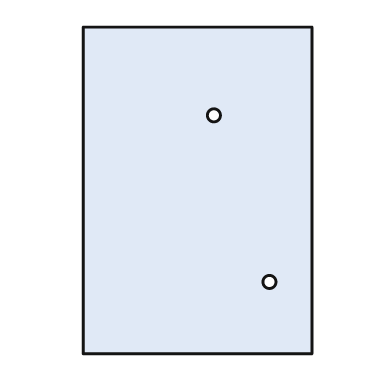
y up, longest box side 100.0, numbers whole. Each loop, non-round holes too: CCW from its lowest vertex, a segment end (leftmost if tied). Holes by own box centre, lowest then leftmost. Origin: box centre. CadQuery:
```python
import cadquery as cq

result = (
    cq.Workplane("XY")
    .moveTo(-35.0, -50.0)
    .lineTo(35.0, -50.0)
    .lineTo(35.0, 50.0)
    .lineTo(-35.0, 50.0)
    .close()
    .moveTo(22.0, -28.0)
    .circle(2.0)
    .moveTo(5.0, 23.0)
    .circle(2.0)
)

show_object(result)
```